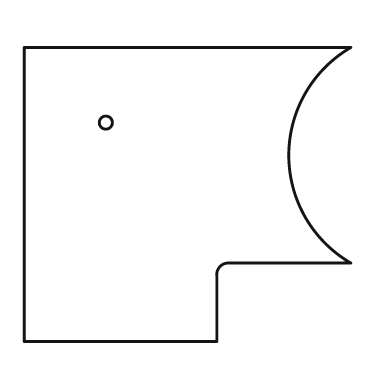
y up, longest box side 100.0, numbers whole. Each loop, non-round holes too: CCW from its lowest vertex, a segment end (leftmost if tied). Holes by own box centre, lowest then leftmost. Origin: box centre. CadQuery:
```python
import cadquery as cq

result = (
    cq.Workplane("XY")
    .moveTo(-50.0, -45.0)
    .lineTo(9.0, -45.0)
    .lineTo(9.0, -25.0)
    .threePointArc((10.0, -22.0), (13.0, -21.0))
    .lineTo(50.0, -21.0)
    .threePointArc((31.0, 12.0), (50.0, 45.0))
    .lineTo(-50.0, 45.0)
    .close()
    .moveTo(-25.0, 22.0)
    .circle(2.0)
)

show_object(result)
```